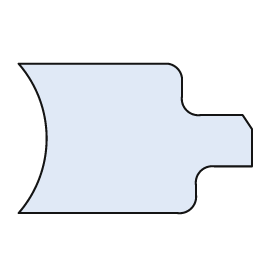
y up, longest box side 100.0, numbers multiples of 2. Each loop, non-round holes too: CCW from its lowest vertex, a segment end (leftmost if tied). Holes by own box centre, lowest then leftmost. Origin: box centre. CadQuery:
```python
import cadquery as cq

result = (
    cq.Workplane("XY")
    .moveTo(-50.0, -32.0)
    .lineTo(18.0, -32.0)
    .threePointArc((24.0, -30.0), (26.0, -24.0))
    .lineTo(26.0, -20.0)
    .threePointArc((28.0, -14.0), (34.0, -12.0))
    .lineTo(50.0, -12.0)
    .lineTo(50.0, 4.0)
    .lineTo(46.0, 10.0)
    .lineTo(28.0, 10.0)
    .threePointArc((22.0, 12.0), (20.0, 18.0))
    .lineTo(20.0, 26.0)
    .threePointArc((18.0, 30.0), (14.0, 32.0))
    .lineTo(-50.0, 32.0)
    .threePointArc((-38.0, 0.0), (-50.0, -32.0))
    .close()
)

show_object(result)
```